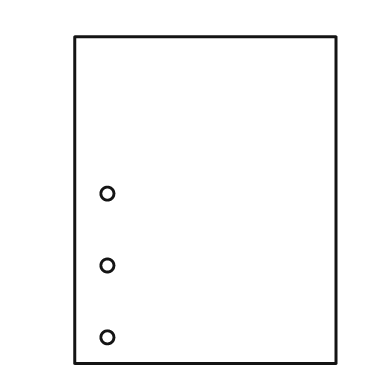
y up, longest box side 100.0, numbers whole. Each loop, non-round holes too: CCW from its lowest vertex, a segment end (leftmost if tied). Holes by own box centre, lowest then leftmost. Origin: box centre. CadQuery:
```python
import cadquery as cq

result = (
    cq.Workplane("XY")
    .moveTo(-40.0, -50.0)
    .lineTo(40.0, -50.0)
    .lineTo(40.0, 50.0)
    .lineTo(-40.0, 50.0)
    .close()
    .moveTo(-30.0, -42.0)
    .circle(2.0)
    .moveTo(-30.0, -20.0)
    .circle(2.0)
    .moveTo(-30.0, 2.0)
    .circle(2.0)
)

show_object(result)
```